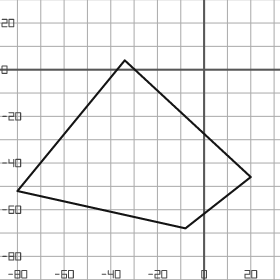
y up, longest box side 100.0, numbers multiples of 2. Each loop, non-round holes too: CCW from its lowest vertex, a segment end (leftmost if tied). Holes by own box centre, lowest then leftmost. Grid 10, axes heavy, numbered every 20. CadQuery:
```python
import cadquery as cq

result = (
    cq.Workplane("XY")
    .moveTo(-8.0, -68.0)
    .lineTo(20.0, -46.0)
    .lineTo(-34.0, 4.0)
    .lineTo(-80.0, -52.0)
    .close()
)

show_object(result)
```